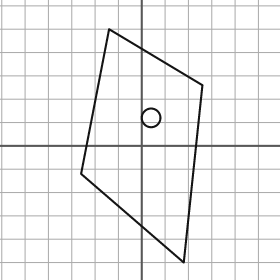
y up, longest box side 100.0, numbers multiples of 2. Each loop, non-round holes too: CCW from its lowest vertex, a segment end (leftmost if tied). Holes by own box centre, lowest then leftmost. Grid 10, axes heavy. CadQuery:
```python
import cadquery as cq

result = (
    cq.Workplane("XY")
    .moveTo(18.0, -50.0)
    .lineTo(26.0, 26.0)
    .lineTo(-14.0, 50.0)
    .lineTo(-26.0, -12.0)
    .close()
    .moveTo(4.0, 12.0)
    .circle(4.0)
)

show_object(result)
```